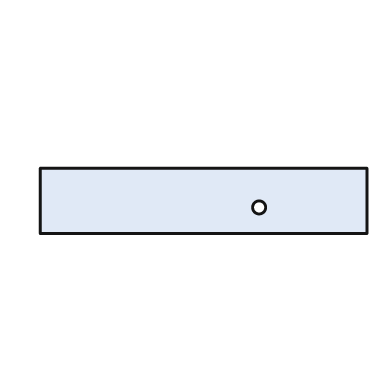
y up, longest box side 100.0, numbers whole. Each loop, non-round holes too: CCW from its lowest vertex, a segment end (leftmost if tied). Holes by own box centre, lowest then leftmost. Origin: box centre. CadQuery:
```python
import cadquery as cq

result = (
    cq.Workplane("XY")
    .moveTo(-50.0, -10.0)
    .lineTo(50.0, -10.0)
    .lineTo(50.0, 10.0)
    .lineTo(-50.0, 10.0)
    .close()
    .moveTo(17.0, -2.0)
    .circle(2.0)
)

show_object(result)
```